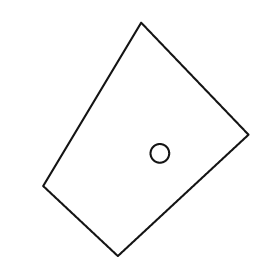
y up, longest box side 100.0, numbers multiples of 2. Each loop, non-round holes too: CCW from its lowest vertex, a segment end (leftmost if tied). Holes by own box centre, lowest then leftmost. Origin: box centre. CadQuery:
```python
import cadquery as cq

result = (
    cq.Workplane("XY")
    .moveTo(-12.0, -50.0)
    .lineTo(44.0, 2.0)
    .lineTo(-2.0, 50.0)
    .lineTo(-44.0, -20.0)
    .close()
    .moveTo(6.0, -6.0)
    .circle(4.0)
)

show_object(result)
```